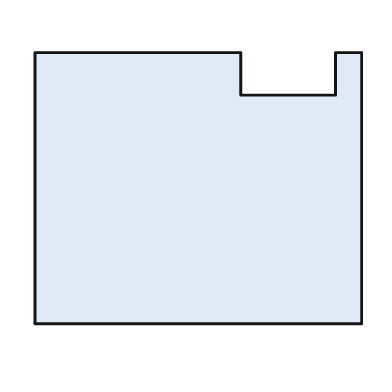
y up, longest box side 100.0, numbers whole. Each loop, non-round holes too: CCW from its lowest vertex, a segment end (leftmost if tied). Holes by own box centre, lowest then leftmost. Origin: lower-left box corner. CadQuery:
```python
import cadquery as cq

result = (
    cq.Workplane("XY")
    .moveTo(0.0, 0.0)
    .lineTo(100.0, 0.0)
    .lineTo(100.0, 83.0)
    .lineTo(92.0, 83.0)
    .lineTo(92.0, 70.0)
    .lineTo(63.0, 70.0)
    .lineTo(63.0, 83.0)
    .lineTo(0.0, 83.0)
    .close()
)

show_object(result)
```